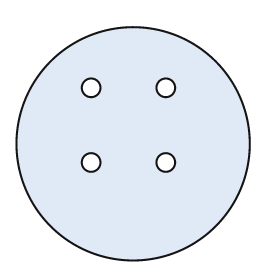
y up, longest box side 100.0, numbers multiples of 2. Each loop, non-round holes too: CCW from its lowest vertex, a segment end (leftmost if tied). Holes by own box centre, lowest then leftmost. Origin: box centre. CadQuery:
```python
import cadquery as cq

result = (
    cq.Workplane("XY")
    .moveTo(0.0, 0.0)
    .circle(50.0)
    .moveTo(-18.0, -8.0)
    .circle(4.0)
    .moveTo(14.0, -8.0)
    .circle(4.0)
    .moveTo(-18.0, 24.0)
    .circle(4.0)
    .moveTo(14.0, 24.0)
    .circle(4.0)
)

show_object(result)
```